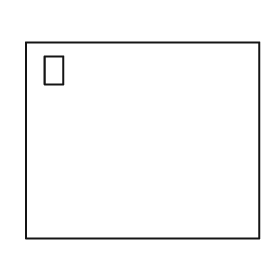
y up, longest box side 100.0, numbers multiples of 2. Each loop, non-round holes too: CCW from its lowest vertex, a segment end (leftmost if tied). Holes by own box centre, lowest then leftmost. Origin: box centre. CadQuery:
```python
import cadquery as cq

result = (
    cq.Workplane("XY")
    .moveTo(-50.0, -42.0)
    .lineTo(50.0, -42.0)
    .lineTo(50.0, 42.0)
    .lineTo(-50.0, 42.0)
    .close()
    .moveTo(-42.0, 24.0)
    .lineTo(-34.0, 24.0)
    .lineTo(-34.0, 36.0)
    .lineTo(-42.0, 36.0)
    .close()
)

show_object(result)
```